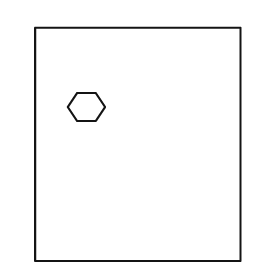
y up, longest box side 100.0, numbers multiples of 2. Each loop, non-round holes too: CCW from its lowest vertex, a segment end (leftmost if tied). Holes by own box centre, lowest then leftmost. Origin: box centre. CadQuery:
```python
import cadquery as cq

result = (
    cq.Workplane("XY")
    .moveTo(-44.0, -50.0)
    .lineTo(44.0, -50.0)
    .lineTo(44.0, 50.0)
    .lineTo(-44.0, 50.0)
    .close()
    .moveTo(-26.0, 10.0)
    .lineTo(-18.0, 10.0)
    .lineTo(-14.0, 16.0)
    .lineTo(-18.0, 22.0)
    .lineTo(-26.0, 22.0)
    .lineTo(-30.0, 16.0)
    .close()
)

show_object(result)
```